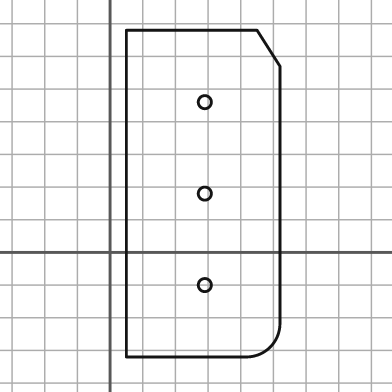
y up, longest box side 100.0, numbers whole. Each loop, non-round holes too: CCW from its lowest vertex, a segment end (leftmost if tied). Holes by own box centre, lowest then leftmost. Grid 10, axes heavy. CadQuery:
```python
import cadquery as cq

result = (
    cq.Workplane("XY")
    .moveTo(5.0, -32.0)
    .lineTo(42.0, -32.0)
    .threePointArc((49.0, -29.0), (52.0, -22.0))
    .lineTo(52.0, 57.0)
    .lineTo(45.0, 68.0)
    .lineTo(5.0, 68.0)
    .close()
    .moveTo(29.0, -10.0)
    .circle(2.0)
    .moveTo(29.0, 18.0)
    .circle(2.0)
    .moveTo(29.0, 46.0)
    .circle(2.0)
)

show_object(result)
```